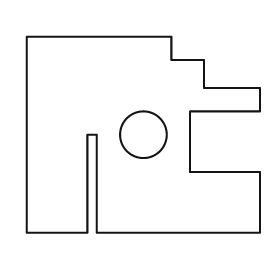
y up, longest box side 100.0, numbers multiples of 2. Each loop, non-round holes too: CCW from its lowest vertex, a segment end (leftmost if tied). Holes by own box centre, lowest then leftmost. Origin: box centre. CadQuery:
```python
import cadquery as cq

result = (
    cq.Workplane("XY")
    .moveTo(-50.0, -42.0)
    .lineTo(-24.0, -42.0)
    .lineTo(-24.0, 0.0)
    .lineTo(-20.0, 0.0)
    .lineTo(-20.0, -42.0)
    .lineTo(50.0, -42.0)
    .lineTo(50.0, -16.0)
    .lineTo(20.0, -16.0)
    .lineTo(20.0, 10.0)
    .lineTo(50.0, 10.0)
    .lineTo(50.0, 20.0)
    .lineTo(26.0, 20.0)
    .lineTo(26.0, 32.0)
    .lineTo(12.0, 32.0)
    .lineTo(12.0, 42.0)
    .lineTo(-50.0, 42.0)
    .close()
    .moveTo(0.0, 0.0)
    .circle(10.0)
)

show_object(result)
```